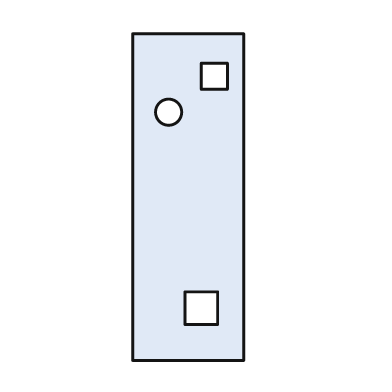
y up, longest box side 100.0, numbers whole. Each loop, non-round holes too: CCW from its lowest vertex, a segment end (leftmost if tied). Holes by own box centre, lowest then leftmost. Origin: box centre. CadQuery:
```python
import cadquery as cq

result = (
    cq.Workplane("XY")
    .moveTo(-17.0, -50.0)
    .lineTo(17.0, -50.0)
    .lineTo(17.0, 50.0)
    .lineTo(-17.0, 50.0)
    .close()
    .moveTo(-1.0, -39.0)
    .lineTo(9.0, -39.0)
    .lineTo(9.0, -29.0)
    .lineTo(-1.0, -29.0)
    .close()
    .moveTo(-6.0, 26.0)
    .circle(4.0)
    .moveTo(4.0, 33.0)
    .lineTo(12.0, 33.0)
    .lineTo(12.0, 41.0)
    .lineTo(4.0, 41.0)
    .close()
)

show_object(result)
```